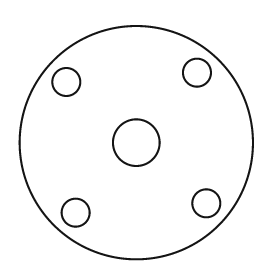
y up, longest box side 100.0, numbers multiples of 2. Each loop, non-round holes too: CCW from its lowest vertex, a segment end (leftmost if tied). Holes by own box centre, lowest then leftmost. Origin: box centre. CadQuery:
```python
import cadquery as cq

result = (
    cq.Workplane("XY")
    .moveTo(0.0, 0.0)
    .circle(50.0)
    .moveTo(-26.0, -30.0)
    .circle(6.0)
    .moveTo(30.0, -26.0)
    .circle(6.0)
    .moveTo(0.0, 0.0)
    .circle(10.0)
    .moveTo(-30.0, 26.0)
    .circle(6.0)
    .moveTo(26.0, 30.0)
    .circle(6.0)
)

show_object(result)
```